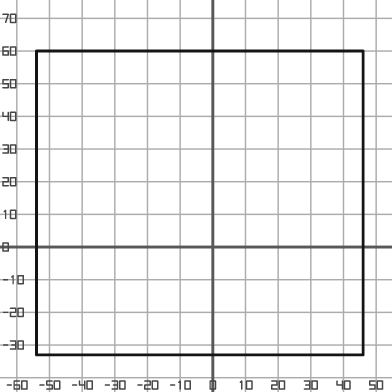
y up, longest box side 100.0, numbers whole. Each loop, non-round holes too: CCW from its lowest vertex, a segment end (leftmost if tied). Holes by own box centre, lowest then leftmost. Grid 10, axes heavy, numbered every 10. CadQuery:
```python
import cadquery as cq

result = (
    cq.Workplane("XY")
    .moveTo(-54.0, -33.0)
    .lineTo(46.0, -33.0)
    .lineTo(46.0, 60.0)
    .lineTo(-54.0, 60.0)
    .close()
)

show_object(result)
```